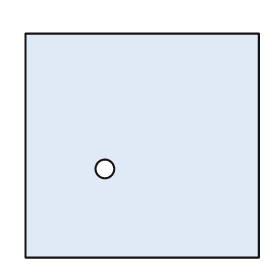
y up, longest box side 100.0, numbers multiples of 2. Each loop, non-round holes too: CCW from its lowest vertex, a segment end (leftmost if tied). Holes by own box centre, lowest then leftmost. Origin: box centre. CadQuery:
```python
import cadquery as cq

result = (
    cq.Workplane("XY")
    .moveTo(-50.0, -48.0)
    .lineTo(50.0, -48.0)
    .lineTo(50.0, 48.0)
    .lineTo(-50.0, 48.0)
    .close()
    .moveTo(-16.0, -10.0)
    .circle(4.0)
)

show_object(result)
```